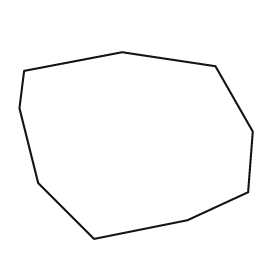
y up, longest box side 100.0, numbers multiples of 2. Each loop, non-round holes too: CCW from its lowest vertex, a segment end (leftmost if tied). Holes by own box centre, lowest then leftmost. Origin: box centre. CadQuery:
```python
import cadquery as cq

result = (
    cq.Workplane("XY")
    .moveTo(-18.0, -40.0)
    .lineTo(22.0, -32.0)
    .lineTo(48.0, -20.0)
    .lineTo(50.0, 6.0)
    .lineTo(34.0, 34.0)
    .lineTo(-6.0, 40.0)
    .lineTo(-48.0, 32.0)
    .lineTo(-50.0, 16.0)
    .lineTo(-42.0, -16.0)
    .close()
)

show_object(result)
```